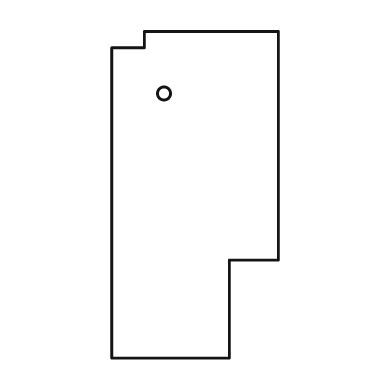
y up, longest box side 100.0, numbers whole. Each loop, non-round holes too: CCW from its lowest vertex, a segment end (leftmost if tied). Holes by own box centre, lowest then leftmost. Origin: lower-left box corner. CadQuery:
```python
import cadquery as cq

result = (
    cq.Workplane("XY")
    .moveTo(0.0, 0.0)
    .lineTo(36.0, 0.0)
    .lineTo(36.0, 30.0)
    .lineTo(51.0, 30.0)
    .lineTo(51.0, 100.0)
    .lineTo(10.0, 100.0)
    .lineTo(10.0, 95.0)
    .lineTo(0.0, 95.0)
    .close()
    .moveTo(16.0, 81.0)
    .circle(2.0)
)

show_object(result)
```